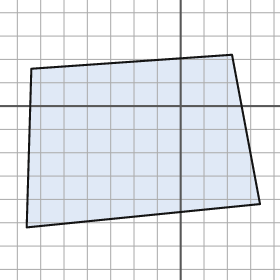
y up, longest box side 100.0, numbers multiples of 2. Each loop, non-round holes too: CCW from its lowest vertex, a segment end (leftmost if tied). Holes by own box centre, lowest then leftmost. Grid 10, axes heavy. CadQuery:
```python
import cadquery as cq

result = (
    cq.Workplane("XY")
    .moveTo(-66.0, -52.0)
    .lineTo(34.0, -42.0)
    .lineTo(22.0, 22.0)
    .lineTo(-64.0, 16.0)
    .close()
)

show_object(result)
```